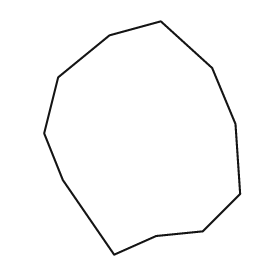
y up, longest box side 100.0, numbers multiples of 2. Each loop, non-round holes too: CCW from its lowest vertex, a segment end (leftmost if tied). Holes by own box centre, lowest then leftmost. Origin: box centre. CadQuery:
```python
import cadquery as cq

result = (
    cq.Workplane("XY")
    .moveTo(-12.0, -50.0)
    .lineTo(6.0, -42.0)
    .lineTo(26.0, -40.0)
    .lineTo(42.0, -24.0)
    .lineTo(40.0, 6.0)
    .lineTo(30.0, 30.0)
    .lineTo(8.0, 50.0)
    .lineTo(-14.0, 44.0)
    .lineTo(-36.0, 26.0)
    .lineTo(-42.0, 2.0)
    .lineTo(-34.0, -18.0)
    .close()
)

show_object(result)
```